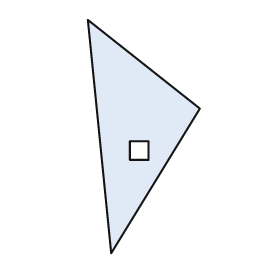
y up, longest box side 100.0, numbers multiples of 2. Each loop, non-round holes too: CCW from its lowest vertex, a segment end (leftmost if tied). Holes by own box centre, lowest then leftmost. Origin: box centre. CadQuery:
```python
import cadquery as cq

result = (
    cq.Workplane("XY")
    .moveTo(-14.0, -50.0)
    .lineTo(24.0, 12.0)
    .lineTo(-24.0, 50.0)
    .close()
    .moveTo(-6.0, -10.0)
    .lineTo(2.0, -10.0)
    .lineTo(2.0, -2.0)
    .lineTo(-6.0, -2.0)
    .close()
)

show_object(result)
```